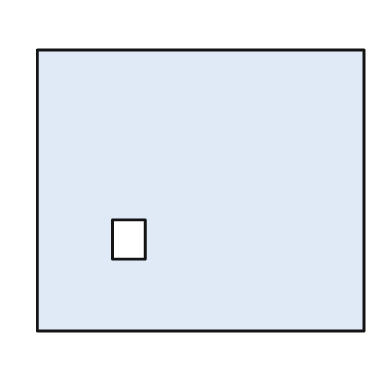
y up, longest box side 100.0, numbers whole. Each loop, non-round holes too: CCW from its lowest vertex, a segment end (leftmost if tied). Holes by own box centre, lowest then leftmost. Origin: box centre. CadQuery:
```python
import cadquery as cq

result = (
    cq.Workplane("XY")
    .moveTo(-50.0, -43.0)
    .lineTo(50.0, -43.0)
    .lineTo(50.0, 43.0)
    .lineTo(-50.0, 43.0)
    .close()
    .moveTo(-27.0, -21.0)
    .lineTo(-17.0, -21.0)
    .lineTo(-17.0, -9.0)
    .lineTo(-27.0, -9.0)
    .close()
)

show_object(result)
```